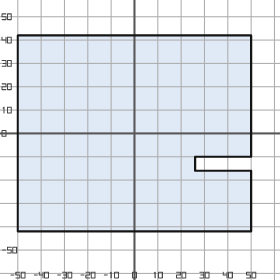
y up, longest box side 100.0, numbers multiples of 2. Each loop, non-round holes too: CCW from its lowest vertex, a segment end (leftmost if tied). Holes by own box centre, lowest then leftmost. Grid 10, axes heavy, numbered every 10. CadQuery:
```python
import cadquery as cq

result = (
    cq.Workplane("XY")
    .moveTo(-50.0, -42.0)
    .lineTo(50.0, -42.0)
    .lineTo(50.0, -16.0)
    .lineTo(26.0, -16.0)
    .lineTo(26.0, -10.0)
    .lineTo(50.0, -10.0)
    .lineTo(50.0, 42.0)
    .lineTo(-50.0, 42.0)
    .close()
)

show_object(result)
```